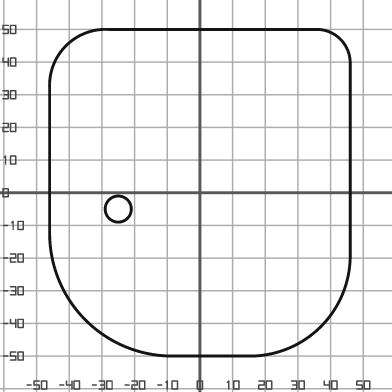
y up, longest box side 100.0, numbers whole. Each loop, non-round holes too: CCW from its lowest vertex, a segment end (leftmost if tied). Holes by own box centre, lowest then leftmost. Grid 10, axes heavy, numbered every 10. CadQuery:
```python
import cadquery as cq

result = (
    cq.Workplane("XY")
    .moveTo(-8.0, -50.0)
    .lineTo(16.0, -50.0)
    .threePointArc((37.0, -41.0), (46.0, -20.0))
    .lineTo(46.0, 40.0)
    .threePointArc((43.0, 47.0), (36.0, 50.0))
    .lineTo(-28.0, 50.0)
    .threePointArc((-41.0, 45.0), (-46.0, 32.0))
    .lineTo(-46.0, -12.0)
    .threePointArc((-35.0, -39.0), (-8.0, -50.0))
    .close()
    .moveTo(-25.0, -5.0)
    .circle(4.0)
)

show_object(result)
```